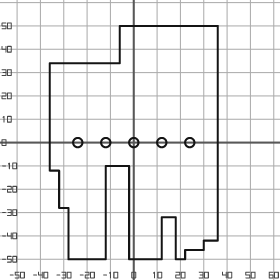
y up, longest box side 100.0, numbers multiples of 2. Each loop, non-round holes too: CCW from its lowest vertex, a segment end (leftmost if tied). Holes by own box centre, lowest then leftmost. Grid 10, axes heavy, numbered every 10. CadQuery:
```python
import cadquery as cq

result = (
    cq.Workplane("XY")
    .moveTo(-28.0, -50.0)
    .lineTo(-12.0, -50.0)
    .lineTo(-12.0, -10.0)
    .lineTo(-2.0, -10.0)
    .lineTo(-2.0, -50.0)
    .lineTo(12.0, -50.0)
    .lineTo(12.0, -32.0)
    .lineTo(18.0, -32.0)
    .lineTo(18.0, -50.0)
    .lineTo(22.0, -50.0)
    .lineTo(22.0, -46.0)
    .lineTo(30.0, -46.0)
    .lineTo(30.0, -42.0)
    .lineTo(36.0, -42.0)
    .lineTo(36.0, 50.0)
    .lineTo(-6.0, 50.0)
    .lineTo(-6.0, 34.0)
    .lineTo(-36.0, 34.0)
    .lineTo(-36.0, -12.0)
    .lineTo(-32.0, -12.0)
    .lineTo(-32.0, -28.0)
    .lineTo(-28.0, -28.0)
    .close()
    .moveTo(-24.0, 0.0)
    .circle(2.0)
    .moveTo(-12.0, 0.0)
    .circle(2.0)
    .moveTo(0.0, 0.0)
    .circle(2.0)
    .moveTo(12.0, 0.0)
    .circle(2.0)
    .moveTo(24.0, 0.0)
    .circle(2.0)
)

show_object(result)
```